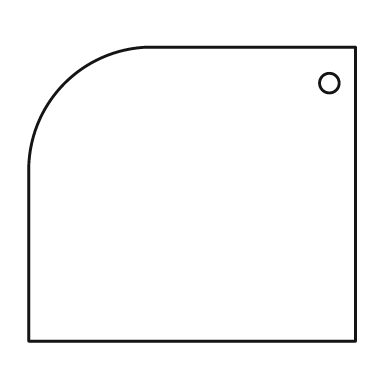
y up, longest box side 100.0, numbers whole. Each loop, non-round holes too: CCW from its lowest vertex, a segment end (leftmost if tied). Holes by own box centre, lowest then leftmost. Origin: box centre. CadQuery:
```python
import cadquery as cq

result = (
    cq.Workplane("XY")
    .moveTo(-50.0, -45.0)
    .lineTo(50.0, -45.0)
    .lineTo(50.0, 45.0)
    .lineTo(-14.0, 45.0)
    .threePointArc((-39.0, 34.0), (-50.0, 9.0))
    .close()
    .moveTo(42.0, 34.0)
    .circle(3.0)
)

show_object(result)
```